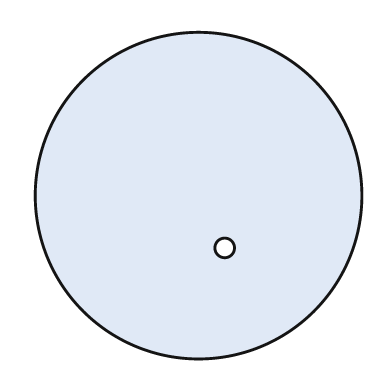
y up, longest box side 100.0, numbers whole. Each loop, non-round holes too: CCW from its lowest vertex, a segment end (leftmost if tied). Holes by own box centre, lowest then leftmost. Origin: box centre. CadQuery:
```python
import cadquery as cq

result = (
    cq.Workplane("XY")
    .moveTo(0.0, 0.0)
    .circle(50.0)
    .moveTo(8.0, -16.0)
    .circle(3.0)
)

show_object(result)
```